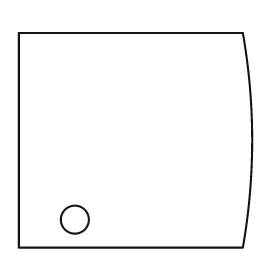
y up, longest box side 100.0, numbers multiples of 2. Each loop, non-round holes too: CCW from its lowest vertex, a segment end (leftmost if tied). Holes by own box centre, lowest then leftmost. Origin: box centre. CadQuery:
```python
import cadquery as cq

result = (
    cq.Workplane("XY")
    .moveTo(-50.0, -46.0)
    .lineTo(46.0, -46.0)
    .threePointArc((50.0, 0.0), (46.0, 46.0))
    .lineTo(-50.0, 46.0)
    .close()
    .moveTo(-26.0, -34.0)
    .circle(6.0)
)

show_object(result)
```